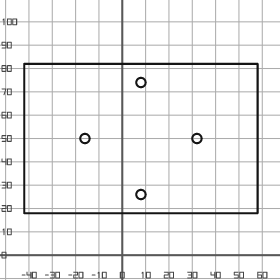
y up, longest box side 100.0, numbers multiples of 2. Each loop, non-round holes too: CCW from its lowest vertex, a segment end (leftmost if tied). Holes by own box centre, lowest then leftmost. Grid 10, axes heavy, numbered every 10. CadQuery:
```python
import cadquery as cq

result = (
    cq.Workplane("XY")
    .moveTo(-42.0, 18.0)
    .lineTo(58.0, 18.0)
    .lineTo(58.0, 82.0)
    .lineTo(-42.0, 82.0)
    .close()
    .moveTo(8.0, 26.0)
    .circle(2.0)
    .moveTo(-16.0, 50.0)
    .circle(2.0)
    .moveTo(32.0, 50.0)
    .circle(2.0)
    .moveTo(8.0, 74.0)
    .circle(2.0)
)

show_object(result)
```